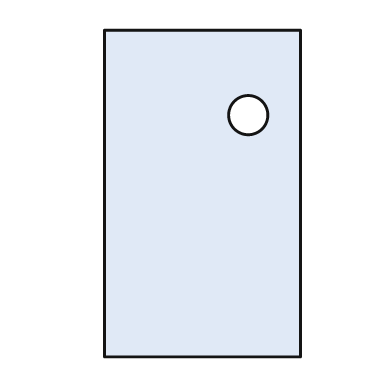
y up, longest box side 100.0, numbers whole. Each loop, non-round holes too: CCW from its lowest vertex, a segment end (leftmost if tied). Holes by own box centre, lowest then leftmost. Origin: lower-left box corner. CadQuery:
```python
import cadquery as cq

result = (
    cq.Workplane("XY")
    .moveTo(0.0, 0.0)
    .lineTo(60.0, 0.0)
    .lineTo(60.0, 100.0)
    .lineTo(0.0, 100.0)
    .close()
    .moveTo(44.0, 74.0)
    .circle(6.0)
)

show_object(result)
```